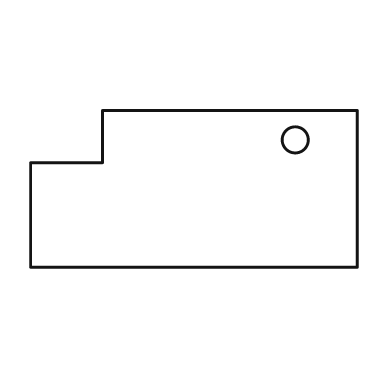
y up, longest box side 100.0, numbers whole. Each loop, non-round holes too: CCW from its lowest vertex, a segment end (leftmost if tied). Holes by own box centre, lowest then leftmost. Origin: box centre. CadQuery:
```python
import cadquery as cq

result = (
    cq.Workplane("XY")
    .moveTo(-50.0, -24.0)
    .lineTo(50.0, -24.0)
    .lineTo(50.0, 24.0)
    .lineTo(-28.0, 24.0)
    .lineTo(-28.0, 8.0)
    .lineTo(-50.0, 8.0)
    .close()
    .moveTo(31.0, 15.0)
    .circle(4.0)
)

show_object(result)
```